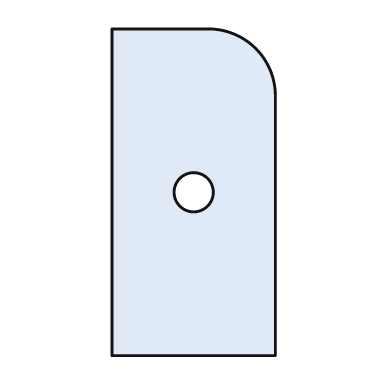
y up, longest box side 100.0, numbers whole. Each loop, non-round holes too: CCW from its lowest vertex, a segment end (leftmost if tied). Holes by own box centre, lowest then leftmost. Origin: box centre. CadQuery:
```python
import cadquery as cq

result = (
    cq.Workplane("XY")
    .moveTo(-25.0, -50.0)
    .lineTo(25.0, -50.0)
    .lineTo(25.0, 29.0)
    .threePointArc((19.0, 44.0), (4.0, 50.0))
    .lineTo(-25.0, 50.0)
    .close()
    .moveTo(0.0, 0.0)
    .circle(6.0)
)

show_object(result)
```